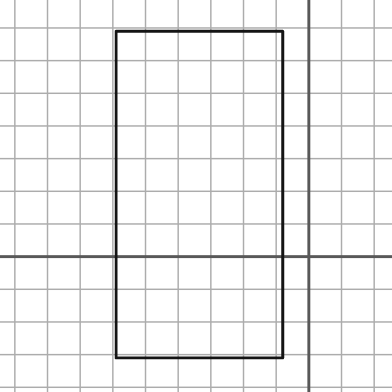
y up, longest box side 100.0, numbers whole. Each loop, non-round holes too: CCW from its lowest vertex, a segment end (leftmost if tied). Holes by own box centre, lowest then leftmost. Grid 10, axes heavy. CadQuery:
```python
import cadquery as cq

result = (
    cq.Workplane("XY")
    .moveTo(-59.0, -31.0)
    .lineTo(-8.0, -31.0)
    .lineTo(-8.0, 69.0)
    .lineTo(-59.0, 69.0)
    .close()
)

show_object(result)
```